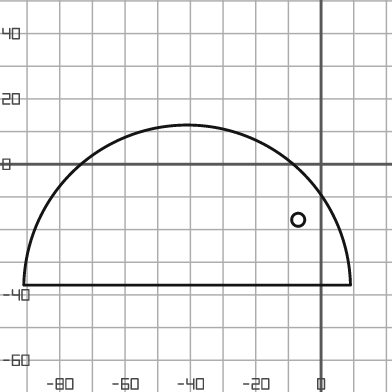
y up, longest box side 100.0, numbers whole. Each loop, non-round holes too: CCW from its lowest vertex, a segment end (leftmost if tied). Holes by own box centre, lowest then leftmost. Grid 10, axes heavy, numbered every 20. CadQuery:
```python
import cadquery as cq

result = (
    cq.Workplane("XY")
    .moveTo(-91.0, -37.0)
    .lineTo(9.0, -37.0)
    .threePointArc((-41.0, 12.0), (-91.0, -37.0))
    .close()
    .moveTo(-7.0, -17.0)
    .circle(2.0)
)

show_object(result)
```